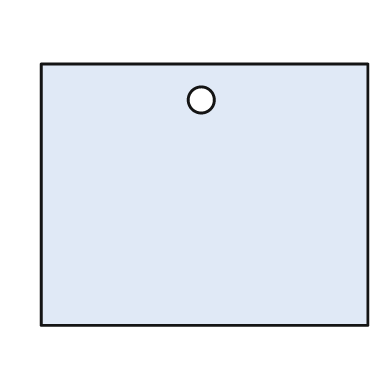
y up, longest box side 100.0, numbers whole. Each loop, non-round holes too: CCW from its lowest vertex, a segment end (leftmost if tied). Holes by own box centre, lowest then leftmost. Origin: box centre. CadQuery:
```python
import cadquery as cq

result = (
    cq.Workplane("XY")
    .moveTo(-50.0, -40.0)
    .lineTo(50.0, -40.0)
    .lineTo(50.0, 40.0)
    .lineTo(-50.0, 40.0)
    .close()
    .moveTo(-1.0, 29.0)
    .circle(4.0)
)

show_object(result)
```